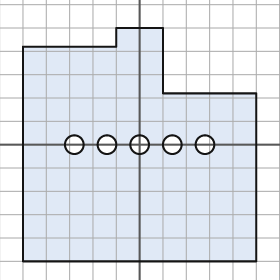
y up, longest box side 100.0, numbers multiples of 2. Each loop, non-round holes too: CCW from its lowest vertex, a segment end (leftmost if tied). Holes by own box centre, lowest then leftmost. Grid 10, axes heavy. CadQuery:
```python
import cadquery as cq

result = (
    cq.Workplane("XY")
    .moveTo(-50.0, -50.0)
    .lineTo(50.0, -50.0)
    .lineTo(50.0, 22.0)
    .lineTo(10.0, 22.0)
    .lineTo(10.0, 50.0)
    .lineTo(-10.0, 50.0)
    .lineTo(-10.0, 42.0)
    .lineTo(-50.0, 42.0)
    .close()
    .moveTo(-28.0, 0.0)
    .circle(4.0)
    .moveTo(-14.0, 0.0)
    .circle(4.0)
    .moveTo(0.0, 0.0)
    .circle(4.0)
    .moveTo(14.0, 0.0)
    .circle(4.0)
    .moveTo(28.0, 0.0)
    .circle(4.0)
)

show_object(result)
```